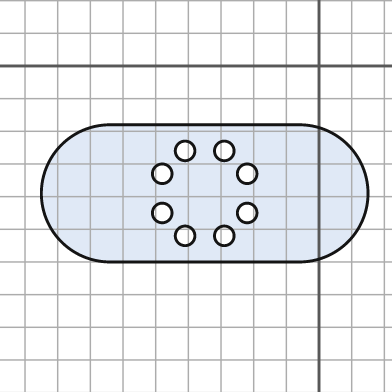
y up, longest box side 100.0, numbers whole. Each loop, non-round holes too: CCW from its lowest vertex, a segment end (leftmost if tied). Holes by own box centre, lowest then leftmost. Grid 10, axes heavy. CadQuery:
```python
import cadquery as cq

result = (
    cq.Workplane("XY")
    .moveTo(-64.0, -60.0)
    .lineTo(-6.0, -60.0)
    .threePointArc((15.0, -39.0), (-6.0, -18.0))
    .lineTo(-64.0, -18.0)
    .threePointArc((-85.0, -39.0), (-64.0, -60.0))
    .close()
    .moveTo(-41.0, -52.0)
    .circle(3.0)
    .moveTo(-29.0, -52.0)
    .circle(3.0)
    .moveTo(-48.0, -45.0)
    .circle(3.0)
    .moveTo(-22.0, -45.0)
    .circle(3.0)
    .moveTo(-48.0, -33.0)
    .circle(3.0)
    .moveTo(-22.0, -33.0)
    .circle(3.0)
    .moveTo(-41.0, -26.0)
    .circle(3.0)
    .moveTo(-29.0, -26.0)
    .circle(3.0)
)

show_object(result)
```